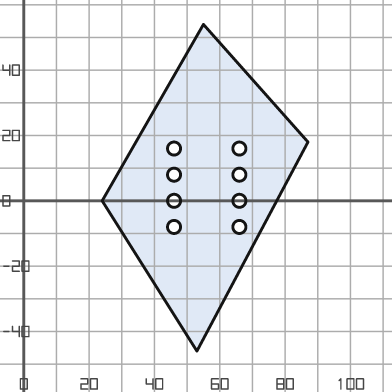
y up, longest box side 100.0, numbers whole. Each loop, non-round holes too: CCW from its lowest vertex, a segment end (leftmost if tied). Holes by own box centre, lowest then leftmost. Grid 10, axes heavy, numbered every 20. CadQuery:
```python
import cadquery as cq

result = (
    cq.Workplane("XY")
    .moveTo(53.0, -46.0)
    .lineTo(87.0, 18.0)
    .lineTo(55.0, 54.0)
    .lineTo(24.0, 0.0)
    .close()
    .moveTo(46.0, -8.0)
    .circle(2.0)
    .moveTo(66.0, -8.0)
    .circle(2.0)
    .moveTo(46.0, 0.0)
    .circle(2.0)
    .moveTo(66.0, 0.0)
    .circle(2.0)
    .moveTo(46.0, 8.0)
    .circle(2.0)
    .moveTo(66.0, 8.0)
    .circle(2.0)
    .moveTo(46.0, 16.0)
    .circle(2.0)
    .moveTo(66.0, 16.0)
    .circle(2.0)
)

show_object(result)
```